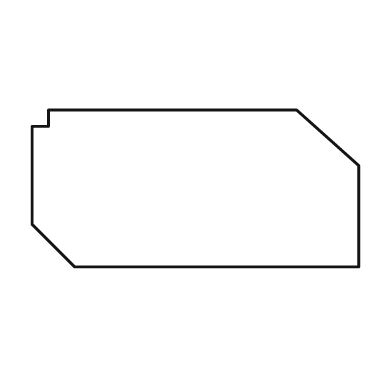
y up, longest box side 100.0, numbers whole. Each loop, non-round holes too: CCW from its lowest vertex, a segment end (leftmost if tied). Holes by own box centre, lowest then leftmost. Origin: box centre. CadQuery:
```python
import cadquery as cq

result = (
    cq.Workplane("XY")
    .moveTo(-37.0, -24.0)
    .lineTo(50.0, -24.0)
    .lineTo(50.0, 7.0)
    .lineTo(31.0, 24.0)
    .lineTo(-45.0, 24.0)
    .lineTo(-45.0, 19.0)
    .lineTo(-50.0, 19.0)
    .lineTo(-50.0, -11.0)
    .close()
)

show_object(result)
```